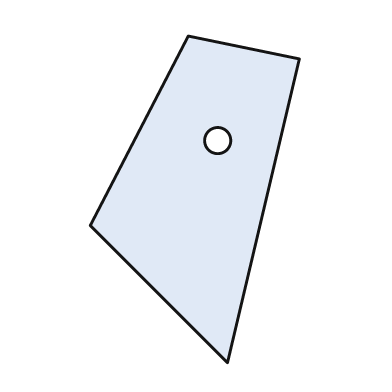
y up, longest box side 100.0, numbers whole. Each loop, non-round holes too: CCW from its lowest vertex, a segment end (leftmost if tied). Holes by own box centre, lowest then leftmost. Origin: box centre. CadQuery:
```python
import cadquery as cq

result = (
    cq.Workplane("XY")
    .moveTo(10.0, -50.0)
    .lineTo(32.0, 43.0)
    .lineTo(-2.0, 50.0)
    .lineTo(-32.0, -8.0)
    .close()
    .moveTo(7.0, 18.0)
    .circle(4.0)
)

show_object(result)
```